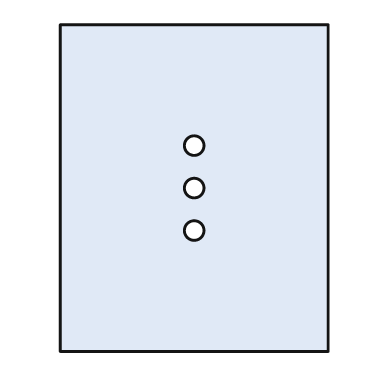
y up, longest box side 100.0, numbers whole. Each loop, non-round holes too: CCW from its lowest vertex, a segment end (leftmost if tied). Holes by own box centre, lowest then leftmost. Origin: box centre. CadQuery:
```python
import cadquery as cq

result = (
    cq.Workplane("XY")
    .moveTo(-41.0, -50.0)
    .lineTo(41.0, -50.0)
    .lineTo(41.0, 50.0)
    .lineTo(-41.0, 50.0)
    .close()
    .moveTo(0.0, -13.0)
    .circle(3.0)
    .moveTo(0.0, 0.0)
    .circle(3.0)
    .moveTo(0.0, 13.0)
    .circle(3.0)
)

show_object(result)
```